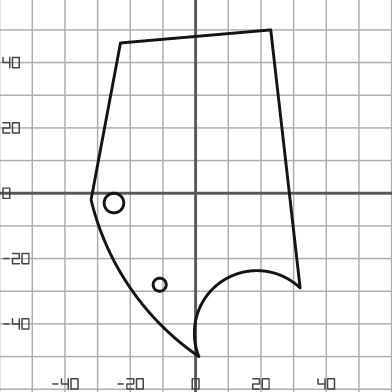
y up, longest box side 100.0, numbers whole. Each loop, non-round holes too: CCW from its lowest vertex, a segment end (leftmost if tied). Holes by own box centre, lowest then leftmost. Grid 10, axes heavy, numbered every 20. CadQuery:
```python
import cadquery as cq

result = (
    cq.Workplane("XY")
    .moveTo(1.0, -50.0)
    .threePointArc((8.0, -27.0), (32.0, -29.0))
    .lineTo(23.0, 50.0)
    .lineTo(-23.0, 46.0)
    .lineTo(-32.0, -2.0)
    .threePointArc((-20.0, -29.0), (1.0, -50.0))
    .close()
    .moveTo(-11.0, -28.0)
    .circle(2.0)
    .moveTo(-25.0, -3.0)
    .circle(3.0)
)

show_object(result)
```